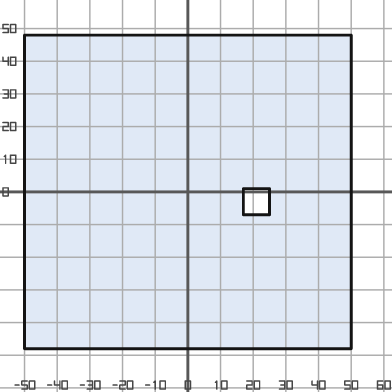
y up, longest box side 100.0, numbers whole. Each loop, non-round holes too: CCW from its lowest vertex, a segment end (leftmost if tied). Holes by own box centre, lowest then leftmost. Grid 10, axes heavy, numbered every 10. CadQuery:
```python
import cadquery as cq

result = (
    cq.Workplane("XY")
    .moveTo(-50.0, -48.0)
    .lineTo(50.0, -48.0)
    .lineTo(50.0, 48.0)
    .lineTo(-50.0, 48.0)
    .close()
    .moveTo(17.0, -7.0)
    .lineTo(25.0, -7.0)
    .lineTo(25.0, 1.0)
    .lineTo(17.0, 1.0)
    .close()
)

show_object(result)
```